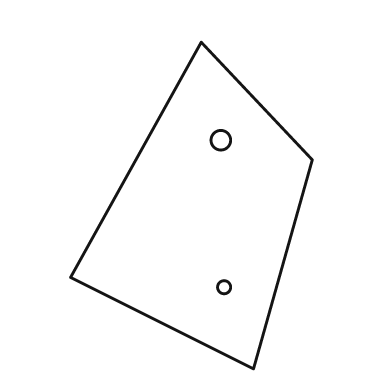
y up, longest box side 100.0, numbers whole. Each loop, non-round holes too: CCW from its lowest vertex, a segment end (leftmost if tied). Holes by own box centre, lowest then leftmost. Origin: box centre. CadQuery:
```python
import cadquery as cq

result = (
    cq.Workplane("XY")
    .moveTo(19.0, -50.0)
    .lineTo(37.0, 14.0)
    .lineTo(3.0, 50.0)
    .lineTo(-37.0, -22.0)
    .close()
    .moveTo(10.0, -25.0)
    .circle(2.0)
    .moveTo(9.0, 20.0)
    .circle(3.0)
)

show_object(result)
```